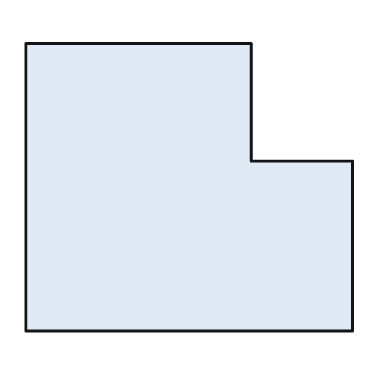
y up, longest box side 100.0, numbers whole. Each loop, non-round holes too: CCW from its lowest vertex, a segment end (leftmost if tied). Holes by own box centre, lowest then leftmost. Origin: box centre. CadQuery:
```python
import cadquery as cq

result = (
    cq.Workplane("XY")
    .moveTo(-50.0, -44.0)
    .lineTo(50.0, -44.0)
    .lineTo(50.0, 8.0)
    .lineTo(19.0, 8.0)
    .lineTo(19.0, 44.0)
    .lineTo(-50.0, 44.0)
    .close()
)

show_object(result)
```